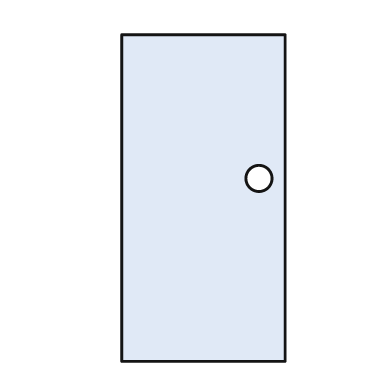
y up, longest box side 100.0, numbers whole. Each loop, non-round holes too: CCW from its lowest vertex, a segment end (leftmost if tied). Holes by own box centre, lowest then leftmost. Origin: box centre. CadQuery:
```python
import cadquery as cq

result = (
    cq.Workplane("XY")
    .moveTo(-25.0, -50.0)
    .lineTo(25.0, -50.0)
    .lineTo(25.0, 50.0)
    .lineTo(-25.0, 50.0)
    .close()
    .moveTo(17.0, 6.0)
    .circle(4.0)
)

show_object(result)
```